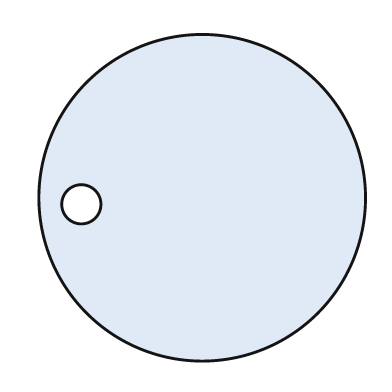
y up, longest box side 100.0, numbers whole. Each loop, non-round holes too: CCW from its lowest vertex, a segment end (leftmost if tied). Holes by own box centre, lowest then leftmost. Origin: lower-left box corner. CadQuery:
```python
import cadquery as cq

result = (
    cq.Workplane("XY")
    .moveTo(50.0, 50.0)
    .circle(50.0)
    .moveTo(13.0, 48.0)
    .circle(6.0)
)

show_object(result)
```